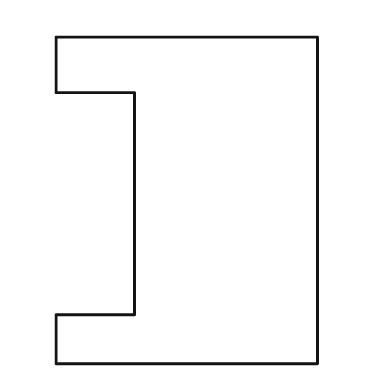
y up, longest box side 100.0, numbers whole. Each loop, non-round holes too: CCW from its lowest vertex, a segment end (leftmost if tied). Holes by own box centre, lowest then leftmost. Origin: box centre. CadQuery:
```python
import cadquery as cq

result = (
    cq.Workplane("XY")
    .moveTo(-40.0, -50.0)
    .lineTo(40.0, -50.0)
    .lineTo(40.0, 50.0)
    .lineTo(-40.0, 50.0)
    .lineTo(-40.0, 33.0)
    .lineTo(-16.0, 33.0)
    .lineTo(-16.0, -35.0)
    .lineTo(-40.0, -35.0)
    .close()
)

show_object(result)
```